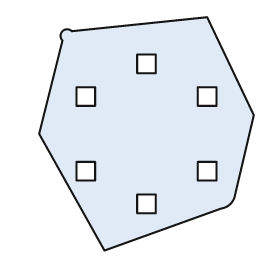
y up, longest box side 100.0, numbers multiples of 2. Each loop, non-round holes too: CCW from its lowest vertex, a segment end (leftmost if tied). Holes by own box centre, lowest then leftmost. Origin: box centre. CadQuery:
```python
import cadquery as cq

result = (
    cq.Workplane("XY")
    .moveTo(-18.0, -50.0)
    .lineTo(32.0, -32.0)
    .threePointArc((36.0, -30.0), (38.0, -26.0))
    .lineTo(46.0, 8.0)
    .lineTo(26.0, 50.0)
    .lineTo(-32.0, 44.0)
    .threePointArc((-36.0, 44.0), (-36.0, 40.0))
    .lineTo(-46.0, 0.0)
    .close()
    .moveTo(-4.0, -34.0)
    .lineTo(4.0, -34.0)
    .lineTo(4.0, -26.0)
    .lineTo(-4.0, -26.0)
    .close()
    .moveTo(-30.0, -20.0)
    .lineTo(-22.0, -20.0)
    .lineTo(-22.0, -12.0)
    .lineTo(-30.0, -12.0)
    .close()
    .moveTo(22.0, -20.0)
    .lineTo(30.0, -20.0)
    .lineTo(30.0, -12.0)
    .lineTo(22.0, -12.0)
    .close()
    .moveTo(-30.0, 12.0)
    .lineTo(-22.0, 12.0)
    .lineTo(-22.0, 20.0)
    .lineTo(-30.0, 20.0)
    .close()
    .moveTo(22.0, 12.0)
    .lineTo(30.0, 12.0)
    .lineTo(30.0, 20.0)
    .lineTo(22.0, 20.0)
    .close()
    .moveTo(-4.0, 26.0)
    .lineTo(4.0, 26.0)
    .lineTo(4.0, 34.0)
    .lineTo(-4.0, 34.0)
    .close()
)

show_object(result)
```